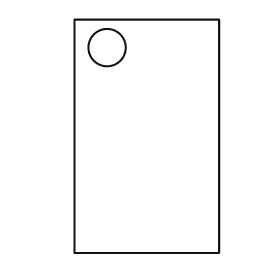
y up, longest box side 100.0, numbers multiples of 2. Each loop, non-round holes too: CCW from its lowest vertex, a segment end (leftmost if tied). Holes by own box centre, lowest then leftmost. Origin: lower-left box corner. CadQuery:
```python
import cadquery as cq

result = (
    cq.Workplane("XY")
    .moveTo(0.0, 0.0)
    .lineTo(62.0, 0.0)
    .lineTo(62.0, 100.0)
    .lineTo(0.0, 100.0)
    .close()
    .moveTo(14.0, 88.0)
    .circle(8.0)
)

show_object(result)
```